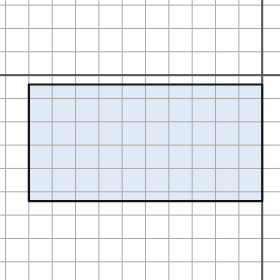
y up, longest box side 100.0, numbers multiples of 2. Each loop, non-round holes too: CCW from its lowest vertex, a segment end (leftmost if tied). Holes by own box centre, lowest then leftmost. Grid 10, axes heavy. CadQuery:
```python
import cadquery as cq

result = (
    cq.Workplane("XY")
    .moveTo(-100.0, -54.0)
    .lineTo(0.0, -54.0)
    .lineTo(0.0, -4.0)
    .lineTo(-100.0, -4.0)
    .close()
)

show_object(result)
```